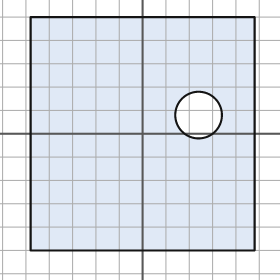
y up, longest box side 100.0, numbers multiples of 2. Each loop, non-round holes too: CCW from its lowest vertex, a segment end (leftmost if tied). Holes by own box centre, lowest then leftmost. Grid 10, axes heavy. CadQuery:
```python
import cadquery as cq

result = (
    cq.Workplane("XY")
    .moveTo(-48.0, -50.0)
    .lineTo(48.0, -50.0)
    .lineTo(48.0, 50.0)
    .lineTo(-48.0, 50.0)
    .close()
    .moveTo(24.0, 8.0)
    .circle(10.0)
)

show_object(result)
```